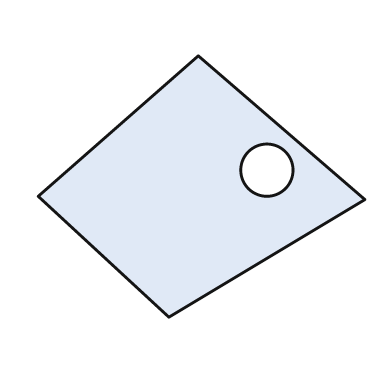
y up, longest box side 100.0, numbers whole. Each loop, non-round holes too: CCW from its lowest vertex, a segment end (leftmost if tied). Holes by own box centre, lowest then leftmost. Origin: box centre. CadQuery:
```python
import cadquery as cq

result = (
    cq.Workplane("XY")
    .moveTo(-10.0, -40.0)
    .lineTo(50.0, -4.0)
    .lineTo(-1.0, 40.0)
    .lineTo(-50.0, -3.0)
    .close()
    .moveTo(20.0, 5.0)
    .circle(8.0)
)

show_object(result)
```